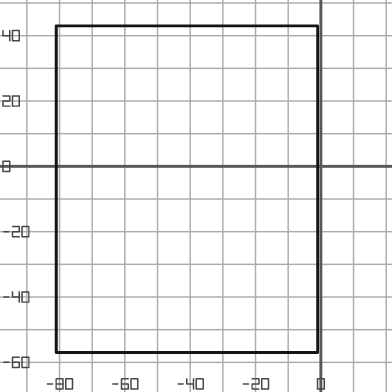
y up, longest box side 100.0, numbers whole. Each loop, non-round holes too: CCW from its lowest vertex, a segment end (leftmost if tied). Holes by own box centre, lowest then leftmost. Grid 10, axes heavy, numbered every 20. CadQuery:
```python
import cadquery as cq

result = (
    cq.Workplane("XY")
    .moveTo(-81.0, -57.0)
    .lineTo(-1.0, -57.0)
    .lineTo(-1.0, 43.0)
    .lineTo(-81.0, 43.0)
    .close()
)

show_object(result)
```